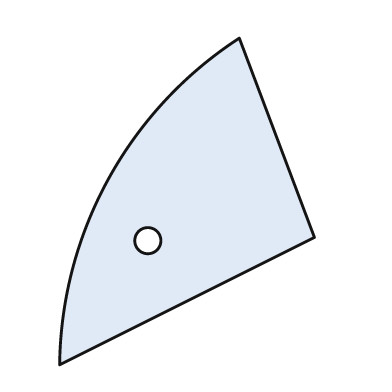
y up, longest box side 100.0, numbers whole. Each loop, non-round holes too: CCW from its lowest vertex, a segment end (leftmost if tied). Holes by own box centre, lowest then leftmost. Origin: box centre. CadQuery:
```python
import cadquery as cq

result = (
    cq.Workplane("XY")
    .moveTo(-39.0, -50.0)
    .lineTo(39.0, -11.0)
    .lineTo(16.0, 50.0)
    .threePointArc((-24.0, 7.0), (-39.0, -50.0))
    .close()
    .moveTo(-12.0, -12.0)
    .circle(4.0)
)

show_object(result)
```